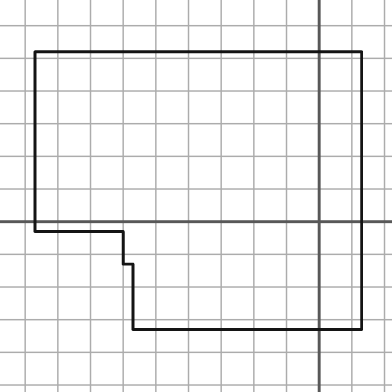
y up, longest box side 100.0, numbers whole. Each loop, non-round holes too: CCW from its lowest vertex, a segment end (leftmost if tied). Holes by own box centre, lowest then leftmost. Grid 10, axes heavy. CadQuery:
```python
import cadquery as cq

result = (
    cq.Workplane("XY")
    .moveTo(-57.0, -33.0)
    .lineTo(13.0, -33.0)
    .lineTo(13.0, 52.0)
    .lineTo(-87.0, 52.0)
    .lineTo(-87.0, -3.0)
    .lineTo(-60.0, -3.0)
    .lineTo(-60.0, -13.0)
    .lineTo(-57.0, -13.0)
    .close()
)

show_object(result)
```